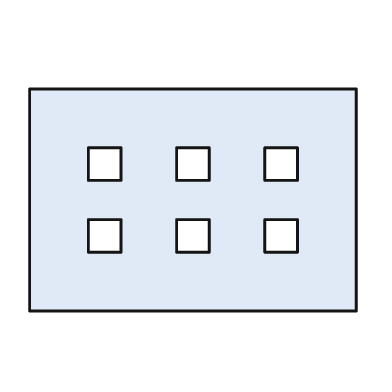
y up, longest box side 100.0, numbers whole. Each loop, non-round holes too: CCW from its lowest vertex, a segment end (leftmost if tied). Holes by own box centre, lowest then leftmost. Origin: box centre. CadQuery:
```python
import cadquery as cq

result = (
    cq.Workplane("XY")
    .moveTo(-50.0, -34.0)
    .lineTo(50.0, -34.0)
    .lineTo(50.0, 34.0)
    .lineTo(-50.0, 34.0)
    .close()
    .moveTo(-32.0, -16.0)
    .lineTo(-22.0, -16.0)
    .lineTo(-22.0, -6.0)
    .lineTo(-32.0, -6.0)
    .close()
    .moveTo(-5.0, -16.0)
    .lineTo(5.0, -16.0)
    .lineTo(5.0, -6.0)
    .lineTo(-5.0, -6.0)
    .close()
    .moveTo(22.0, -16.0)
    .lineTo(32.0, -16.0)
    .lineTo(32.0, -6.0)
    .lineTo(22.0, -6.0)
    .close()
    .moveTo(-32.0, 6.0)
    .lineTo(-22.0, 6.0)
    .lineTo(-22.0, 16.0)
    .lineTo(-32.0, 16.0)
    .close()
    .moveTo(-5.0, 6.0)
    .lineTo(5.0, 6.0)
    .lineTo(5.0, 16.0)
    .lineTo(-5.0, 16.0)
    .close()
    .moveTo(22.0, 6.0)
    .lineTo(32.0, 6.0)
    .lineTo(32.0, 16.0)
    .lineTo(22.0, 16.0)
    .close()
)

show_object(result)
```